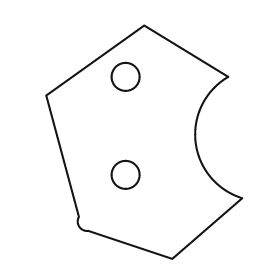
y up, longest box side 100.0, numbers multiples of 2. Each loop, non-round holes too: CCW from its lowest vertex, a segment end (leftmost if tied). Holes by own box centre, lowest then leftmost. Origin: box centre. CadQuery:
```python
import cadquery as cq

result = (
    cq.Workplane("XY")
    .moveTo(12.0, -50.0)
    .lineTo(42.0, -24.0)
    .threePointArc((22.0, 0.0), (36.0, 28.0))
    .lineTo(0.0, 50.0)
    .lineTo(-42.0, 20.0)
    .lineTo(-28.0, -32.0)
    .threePointArc((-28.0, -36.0), (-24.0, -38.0))
    .close()
    .moveTo(-8.0, -14.0)
    .circle(6.0)
    .moveTo(-8.0, 28.0)
    .circle(6.0)
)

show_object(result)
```